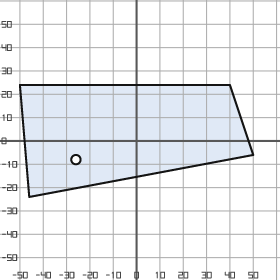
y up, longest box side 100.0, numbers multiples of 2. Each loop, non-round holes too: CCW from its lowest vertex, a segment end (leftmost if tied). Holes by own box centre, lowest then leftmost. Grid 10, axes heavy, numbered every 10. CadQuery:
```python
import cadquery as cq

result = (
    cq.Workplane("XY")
    .moveTo(-46.0, -24.0)
    .lineTo(50.0, -6.0)
    .lineTo(40.0, 24.0)
    .lineTo(-50.0, 24.0)
    .close()
    .moveTo(-26.0, -8.0)
    .circle(2.0)
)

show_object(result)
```